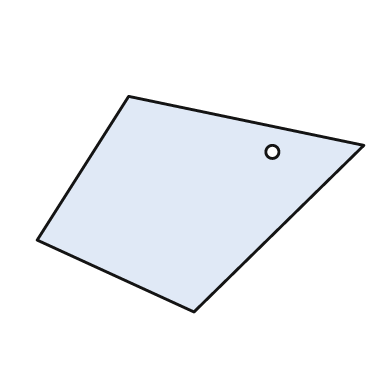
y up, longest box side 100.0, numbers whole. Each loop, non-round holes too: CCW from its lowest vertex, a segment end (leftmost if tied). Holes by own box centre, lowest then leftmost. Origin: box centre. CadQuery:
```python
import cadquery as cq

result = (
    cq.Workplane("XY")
    .moveTo(-2.0, -33.0)
    .lineTo(50.0, 18.0)
    .lineTo(-22.0, 33.0)
    .lineTo(-50.0, -11.0)
    .close()
    .moveTo(22.0, 16.0)
    .circle(2.0)
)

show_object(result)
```